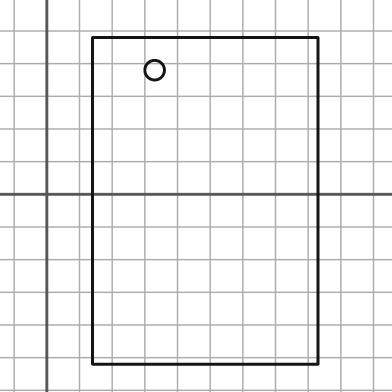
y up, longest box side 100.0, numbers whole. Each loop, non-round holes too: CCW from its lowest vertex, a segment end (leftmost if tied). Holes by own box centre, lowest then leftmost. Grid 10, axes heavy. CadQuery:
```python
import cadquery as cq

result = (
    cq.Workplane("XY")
    .moveTo(14.0, -52.0)
    .lineTo(83.0, -52.0)
    .lineTo(83.0, 48.0)
    .lineTo(14.0, 48.0)
    .close()
    .moveTo(33.0, 38.0)
    .circle(3.0)
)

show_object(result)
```